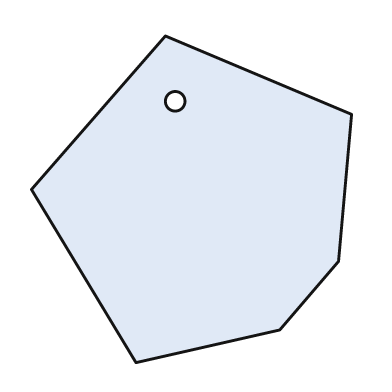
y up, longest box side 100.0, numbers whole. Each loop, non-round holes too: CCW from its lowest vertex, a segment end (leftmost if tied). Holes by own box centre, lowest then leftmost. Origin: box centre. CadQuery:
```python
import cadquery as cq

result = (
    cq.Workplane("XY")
    .moveTo(-17.0, -50.0)
    .lineTo(27.0, -40.0)
    .lineTo(45.0, -19.0)
    .lineTo(49.0, 26.0)
    .lineTo(-8.0, 50.0)
    .lineTo(-49.0, 3.0)
    .close()
    .moveTo(-5.0, 30.0)
    .circle(3.0)
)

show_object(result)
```